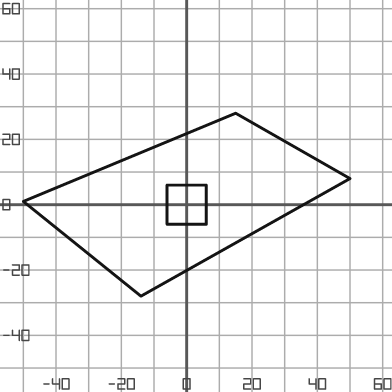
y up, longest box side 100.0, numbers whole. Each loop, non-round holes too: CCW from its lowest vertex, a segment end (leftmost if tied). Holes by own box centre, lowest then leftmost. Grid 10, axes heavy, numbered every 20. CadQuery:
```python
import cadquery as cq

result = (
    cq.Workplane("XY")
    .moveTo(-14.0, -28.0)
    .lineTo(50.0, 8.0)
    .lineTo(15.0, 28.0)
    .lineTo(-50.0, 1.0)
    .close()
    .moveTo(-6.0, -6.0)
    .lineTo(6.0, -6.0)
    .lineTo(6.0, 6.0)
    .lineTo(-6.0, 6.0)
    .close()
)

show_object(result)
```